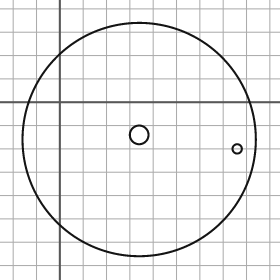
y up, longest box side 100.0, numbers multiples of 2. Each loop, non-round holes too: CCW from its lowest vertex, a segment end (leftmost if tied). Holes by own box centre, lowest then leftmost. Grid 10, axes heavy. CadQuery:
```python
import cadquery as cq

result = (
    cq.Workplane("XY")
    .moveTo(34.0, -16.0)
    .circle(50.0)
    .moveTo(76.0, -20.0)
    .circle(2.0)
    .moveTo(34.0, -14.0)
    .circle(4.0)
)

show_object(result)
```